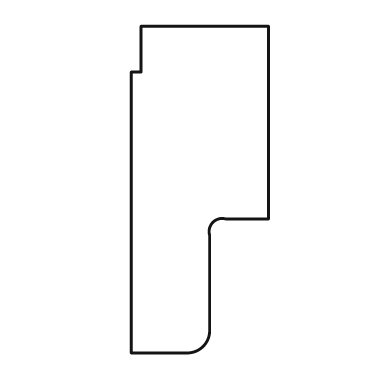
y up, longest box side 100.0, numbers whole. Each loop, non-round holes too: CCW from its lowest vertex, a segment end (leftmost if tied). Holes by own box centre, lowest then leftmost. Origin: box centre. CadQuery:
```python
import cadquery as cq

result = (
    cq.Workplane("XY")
    .moveTo(-21.0, -50.0)
    .lineTo(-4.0, -50.0)
    .threePointArc((1.0, -48.0), (3.0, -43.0))
    .lineTo(3.0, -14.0)
    .threePointArc((4.0, -10.0), (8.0, -9.0))
    .lineTo(21.0, -9.0)
    .lineTo(21.0, 50.0)
    .lineTo(-18.0, 50.0)
    .lineTo(-18.0, 36.0)
    .lineTo(-21.0, 36.0)
    .close()
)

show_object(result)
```